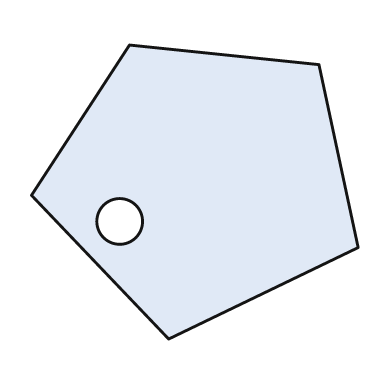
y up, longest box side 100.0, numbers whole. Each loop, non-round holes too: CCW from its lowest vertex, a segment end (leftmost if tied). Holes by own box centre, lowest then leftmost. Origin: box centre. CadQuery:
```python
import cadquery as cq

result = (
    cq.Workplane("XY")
    .moveTo(-8.0, -45.0)
    .lineTo(50.0, -17.0)
    .lineTo(38.0, 39.0)
    .lineTo(-20.0, 45.0)
    .lineTo(-50.0, -1.0)
    .close()
    .moveTo(-23.0, -9.0)
    .circle(7.0)
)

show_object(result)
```